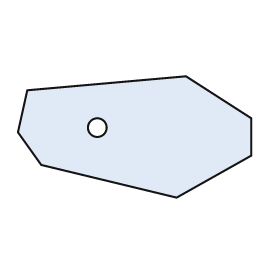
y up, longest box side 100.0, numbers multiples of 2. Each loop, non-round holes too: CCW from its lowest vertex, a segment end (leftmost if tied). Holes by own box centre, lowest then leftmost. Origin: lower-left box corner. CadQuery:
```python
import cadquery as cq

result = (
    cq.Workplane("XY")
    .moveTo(68.0, 0.0)
    .lineTo(100.0, 18.0)
    .lineTo(100.0, 34.0)
    .lineTo(72.0, 52.0)
    .lineTo(4.0, 46.0)
    .lineTo(0.0, 28.0)
    .lineTo(10.0, 14.0)
    .close()
    .moveTo(34.0, 30.0)
    .circle(4.0)
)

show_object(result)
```